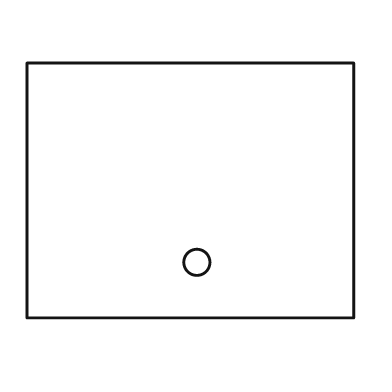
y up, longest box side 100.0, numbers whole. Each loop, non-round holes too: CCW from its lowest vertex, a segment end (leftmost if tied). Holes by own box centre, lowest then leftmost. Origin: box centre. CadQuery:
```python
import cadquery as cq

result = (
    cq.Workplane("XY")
    .moveTo(-50.0, -39.0)
    .lineTo(50.0, -39.0)
    .lineTo(50.0, 39.0)
    .lineTo(-50.0, 39.0)
    .close()
    .moveTo(2.0, -22.0)
    .circle(4.0)
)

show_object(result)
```